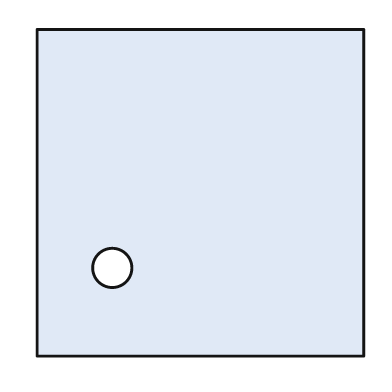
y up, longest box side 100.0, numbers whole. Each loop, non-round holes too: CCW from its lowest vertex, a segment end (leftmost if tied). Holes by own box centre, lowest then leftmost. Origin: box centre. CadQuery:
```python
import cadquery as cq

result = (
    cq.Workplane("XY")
    .moveTo(-50.0, -50.0)
    .lineTo(50.0, -50.0)
    .lineTo(50.0, 50.0)
    .lineTo(-50.0, 50.0)
    .close()
    .moveTo(-27.0, -23.0)
    .circle(6.0)
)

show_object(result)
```